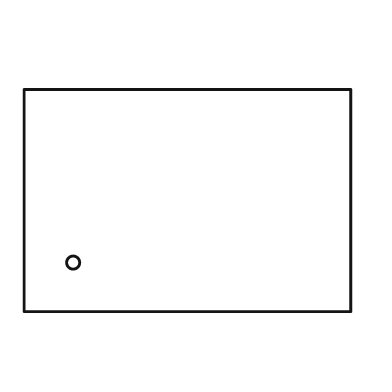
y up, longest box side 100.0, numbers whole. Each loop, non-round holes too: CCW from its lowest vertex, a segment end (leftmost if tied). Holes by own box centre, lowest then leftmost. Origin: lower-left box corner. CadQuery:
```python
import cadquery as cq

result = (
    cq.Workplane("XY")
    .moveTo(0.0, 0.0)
    .lineTo(100.0, 0.0)
    .lineTo(100.0, 68.0)
    .lineTo(0.0, 68.0)
    .close()
    .moveTo(15.0, 15.0)
    .circle(2.0)
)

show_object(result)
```